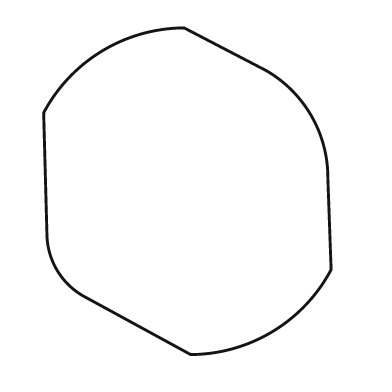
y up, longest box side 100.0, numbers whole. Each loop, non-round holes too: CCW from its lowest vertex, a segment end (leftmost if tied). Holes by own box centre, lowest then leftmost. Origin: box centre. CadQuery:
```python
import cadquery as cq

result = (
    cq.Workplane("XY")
    .moveTo(1.0, -50.0)
    .threePointArc((26.0, -43.0), (44.0, -24.0))
    .lineTo(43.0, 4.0)
    .threePointArc((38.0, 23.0), (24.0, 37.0))
    .lineTo(-1.0, 50.0)
    .threePointArc((-26.0, 43.0), (-44.0, 24.0))
    .lineTo(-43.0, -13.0)
    .threePointArc((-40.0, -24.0), (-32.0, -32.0))
    .close()
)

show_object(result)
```